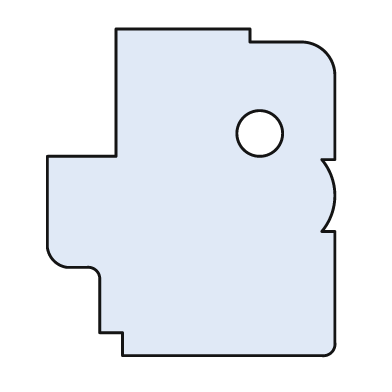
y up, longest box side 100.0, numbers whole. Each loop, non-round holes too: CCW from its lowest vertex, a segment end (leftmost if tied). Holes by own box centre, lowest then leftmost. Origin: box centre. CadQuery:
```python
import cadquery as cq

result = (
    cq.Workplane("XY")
    .moveTo(-21.0, -50.0)
    .lineTo(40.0, -50.0)
    .threePointArc((43.0, -49.0), (44.0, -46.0))
    .lineTo(44.0, -12.0)
    .lineTo(40.0, -12.0)
    .threePointArc((44.0, -1.0), (40.0, 10.0))
    .lineTo(44.0, 10.0)
    .lineTo(44.0, 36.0)
    .threePointArc((41.0, 43.0), (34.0, 46.0))
    .lineTo(18.0, 46.0)
    .lineTo(18.0, 50.0)
    .lineTo(-23.0, 50.0)
    .lineTo(-23.0, 11.0)
    .lineTo(-44.0, 11.0)
    .lineTo(-44.0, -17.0)
    .threePointArc((-42.0, -21.0), (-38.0, -23.0))
    .lineTo(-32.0, -23.0)
    .threePointArc((-29.0, -24.0), (-28.0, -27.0))
    .lineTo(-28.0, -43.0)
    .lineTo(-21.0, -43.0)
    .close()
    .moveTo(21.0, 18.0)
    .circle(7.0)
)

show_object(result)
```